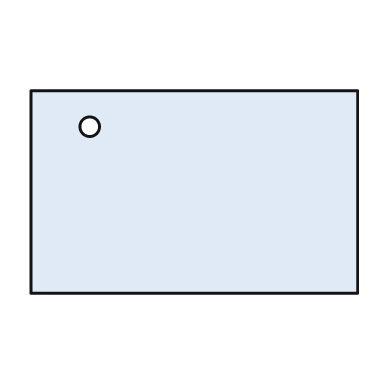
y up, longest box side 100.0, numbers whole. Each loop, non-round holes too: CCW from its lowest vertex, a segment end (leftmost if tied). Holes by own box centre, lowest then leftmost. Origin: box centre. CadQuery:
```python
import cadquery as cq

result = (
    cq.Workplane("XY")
    .moveTo(-50.0, -31.0)
    .lineTo(50.0, -31.0)
    .lineTo(50.0, 31.0)
    .lineTo(-50.0, 31.0)
    .close()
    .moveTo(-32.0, 20.0)
    .circle(3.0)
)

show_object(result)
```